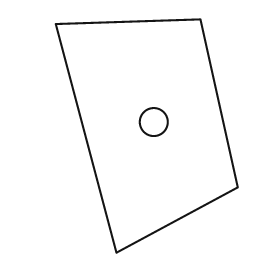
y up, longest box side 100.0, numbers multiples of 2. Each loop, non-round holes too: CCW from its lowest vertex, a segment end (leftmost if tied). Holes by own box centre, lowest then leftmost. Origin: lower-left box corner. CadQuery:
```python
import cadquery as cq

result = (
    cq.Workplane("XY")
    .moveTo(26.0, 0.0)
    .lineTo(78.0, 28.0)
    .lineTo(62.0, 100.0)
    .lineTo(0.0, 98.0)
    .close()
    .moveTo(42.0, 56.0)
    .circle(6.0)
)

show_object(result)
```